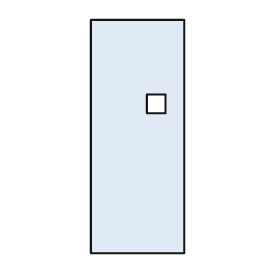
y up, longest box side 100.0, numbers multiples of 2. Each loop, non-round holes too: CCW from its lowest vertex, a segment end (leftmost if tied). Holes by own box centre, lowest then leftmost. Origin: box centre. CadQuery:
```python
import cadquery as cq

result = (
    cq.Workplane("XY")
    .moveTo(-20.0, -50.0)
    .lineTo(20.0, -50.0)
    .lineTo(20.0, 50.0)
    .lineTo(-20.0, 50.0)
    .close()
    .moveTo(4.0, 10.0)
    .lineTo(12.0, 10.0)
    .lineTo(12.0, 18.0)
    .lineTo(4.0, 18.0)
    .close()
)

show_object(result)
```